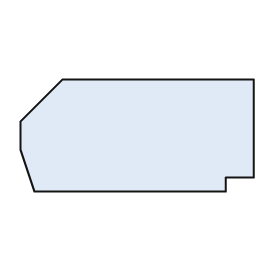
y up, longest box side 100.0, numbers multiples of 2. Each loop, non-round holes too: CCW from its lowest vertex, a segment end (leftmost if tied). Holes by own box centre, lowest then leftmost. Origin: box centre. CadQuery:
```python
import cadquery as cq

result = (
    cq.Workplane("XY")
    .moveTo(-44.0, -24.0)
    .lineTo(38.0, -24.0)
    .lineTo(38.0, -18.0)
    .lineTo(50.0, -18.0)
    .lineTo(50.0, 24.0)
    .lineTo(-32.0, 24.0)
    .lineTo(-50.0, 6.0)
    .lineTo(-50.0, -6.0)
    .close()
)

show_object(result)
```